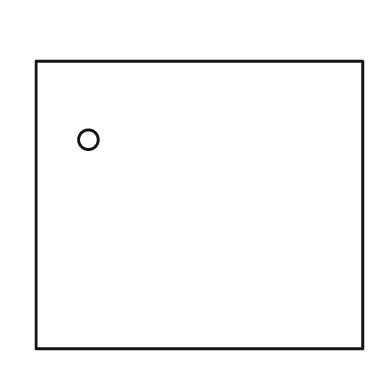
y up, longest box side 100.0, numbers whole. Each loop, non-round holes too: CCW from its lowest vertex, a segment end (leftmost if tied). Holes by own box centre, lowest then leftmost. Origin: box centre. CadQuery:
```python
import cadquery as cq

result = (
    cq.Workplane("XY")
    .moveTo(-50.0, -44.0)
    .lineTo(50.0, -44.0)
    .lineTo(50.0, 44.0)
    .lineTo(-50.0, 44.0)
    .close()
    .moveTo(-34.0, 20.0)
    .circle(3.0)
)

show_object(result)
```